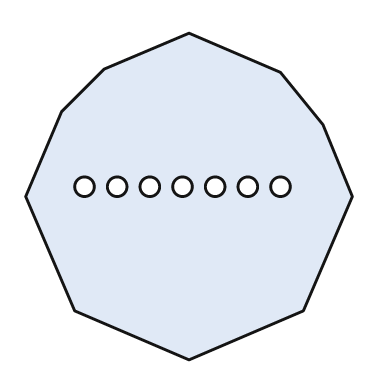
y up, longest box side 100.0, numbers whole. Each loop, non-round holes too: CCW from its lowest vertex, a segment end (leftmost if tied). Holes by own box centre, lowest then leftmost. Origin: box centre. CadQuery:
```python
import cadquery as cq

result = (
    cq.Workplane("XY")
    .moveTo(0.0, -50.0)
    .lineTo(35.0, -35.0)
    .lineTo(50.0, 0.0)
    .lineTo(41.0, 22.0)
    .lineTo(28.0, 38.0)
    .lineTo(0.0, 50.0)
    .lineTo(-26.0, 39.0)
    .lineTo(-39.0, 26.0)
    .lineTo(-50.0, 0.0)
    .lineTo(-35.0, -35.0)
    .close()
    .moveTo(-32.0, 3.0)
    .circle(3.0)
    .moveTo(-22.0, 3.0)
    .circle(3.0)
    .moveTo(-12.0, 3.0)
    .circle(3.0)
    .moveTo(-2.0, 3.0)
    .circle(3.0)
    .moveTo(8.0, 3.0)
    .circle(3.0)
    .moveTo(18.0, 3.0)
    .circle(3.0)
    .moveTo(28.0, 3.0)
    .circle(3.0)
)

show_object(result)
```